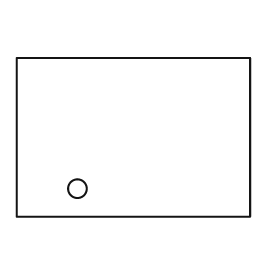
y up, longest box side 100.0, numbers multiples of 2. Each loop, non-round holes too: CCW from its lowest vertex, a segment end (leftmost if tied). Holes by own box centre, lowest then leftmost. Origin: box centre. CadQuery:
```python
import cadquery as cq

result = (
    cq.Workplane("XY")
    .moveTo(-50.0, -34.0)
    .lineTo(50.0, -34.0)
    .lineTo(50.0, 34.0)
    .lineTo(-50.0, 34.0)
    .close()
    .moveTo(-24.0, -22.0)
    .circle(4.0)
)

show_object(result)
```